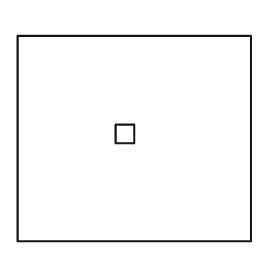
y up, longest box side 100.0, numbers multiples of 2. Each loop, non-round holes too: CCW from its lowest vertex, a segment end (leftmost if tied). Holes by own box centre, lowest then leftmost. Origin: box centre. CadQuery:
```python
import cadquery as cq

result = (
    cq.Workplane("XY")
    .moveTo(-50.0, -44.0)
    .lineTo(50.0, -44.0)
    .lineTo(50.0, 44.0)
    .lineTo(-50.0, 44.0)
    .close()
    .moveTo(-8.0, -2.0)
    .lineTo(0.0, -2.0)
    .lineTo(0.0, 6.0)
    .lineTo(-8.0, 6.0)
    .close()
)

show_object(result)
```